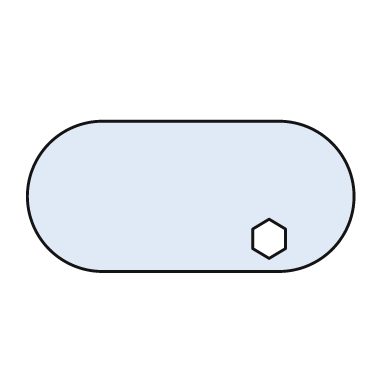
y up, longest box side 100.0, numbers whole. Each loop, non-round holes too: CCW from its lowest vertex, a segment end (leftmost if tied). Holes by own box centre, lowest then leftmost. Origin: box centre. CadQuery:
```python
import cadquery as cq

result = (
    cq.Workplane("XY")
    .moveTo(-27.0, -23.0)
    .lineTo(27.0, -23.0)
    .threePointArc((50.0, 0.0), (27.0, 23.0))
    .lineTo(-27.0, 23.0)
    .threePointArc((-50.0, 0.0), (-27.0, -23.0))
    .close()
    .moveTo(24.0, -19.0)
    .lineTo(29.0, -16.0)
    .lineTo(29.0, -10.0)
    .lineTo(24.0, -7.0)
    .lineTo(19.0, -10.0)
    .lineTo(19.0, -16.0)
    .close()
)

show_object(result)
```